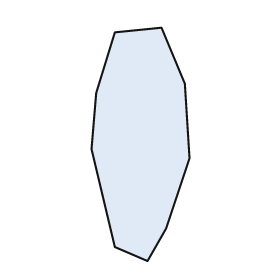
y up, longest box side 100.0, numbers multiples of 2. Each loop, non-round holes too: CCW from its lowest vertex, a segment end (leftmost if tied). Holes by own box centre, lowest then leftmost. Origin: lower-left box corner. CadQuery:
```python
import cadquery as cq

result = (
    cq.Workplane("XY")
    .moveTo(24.0, 0.0)
    .lineTo(32.0, 14.0)
    .lineTo(42.0, 44.0)
    .lineTo(40.0, 76.0)
    .lineTo(30.0, 100.0)
    .lineTo(10.0, 98.0)
    .lineTo(2.0, 72.0)
    .lineTo(0.0, 48.0)
    .lineTo(10.0, 6.0)
    .close()
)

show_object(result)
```